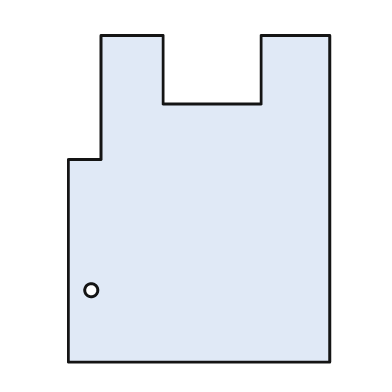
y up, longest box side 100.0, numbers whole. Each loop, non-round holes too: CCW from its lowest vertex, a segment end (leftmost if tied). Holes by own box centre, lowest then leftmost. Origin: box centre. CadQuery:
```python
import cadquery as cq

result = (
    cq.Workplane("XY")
    .moveTo(-40.0, -50.0)
    .lineTo(40.0, -50.0)
    .lineTo(40.0, 50.0)
    .lineTo(19.0, 50.0)
    .lineTo(19.0, 29.0)
    .lineTo(-11.0, 29.0)
    .lineTo(-11.0, 50.0)
    .lineTo(-30.0, 50.0)
    .lineTo(-30.0, 12.0)
    .lineTo(-40.0, 12.0)
    .close()
    .moveTo(-33.0, -28.0)
    .circle(2.0)
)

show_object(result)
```